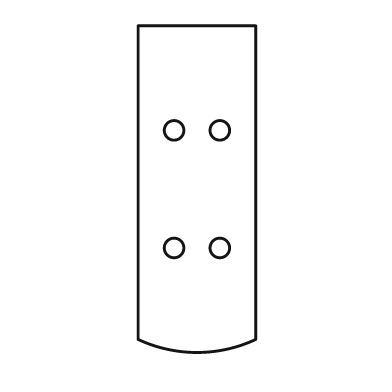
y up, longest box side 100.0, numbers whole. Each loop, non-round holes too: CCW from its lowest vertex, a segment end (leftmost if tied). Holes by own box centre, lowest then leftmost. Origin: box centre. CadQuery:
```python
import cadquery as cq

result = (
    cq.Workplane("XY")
    .moveTo(-18.0, -46.0)
    .threePointArc((0.0, -50.0), (18.0, -46.0))
    .lineTo(18.0, 50.0)
    .lineTo(-18.0, 50.0)
    .close()
    .moveTo(-7.0, -18.0)
    .circle(3.0)
    .moveTo(7.0, -18.0)
    .circle(3.0)
    .moveTo(-7.0, 18.0)
    .circle(3.0)
    .moveTo(7.0, 18.0)
    .circle(3.0)
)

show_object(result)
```